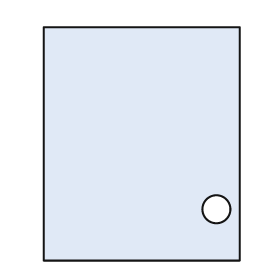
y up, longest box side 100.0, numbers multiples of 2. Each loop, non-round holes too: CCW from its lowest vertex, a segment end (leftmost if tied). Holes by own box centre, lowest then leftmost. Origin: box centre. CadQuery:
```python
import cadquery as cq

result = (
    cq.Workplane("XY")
    .moveTo(-42.0, -50.0)
    .lineTo(42.0, -50.0)
    .lineTo(42.0, 50.0)
    .lineTo(-42.0, 50.0)
    .close()
    .moveTo(32.0, -28.0)
    .circle(6.0)
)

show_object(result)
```